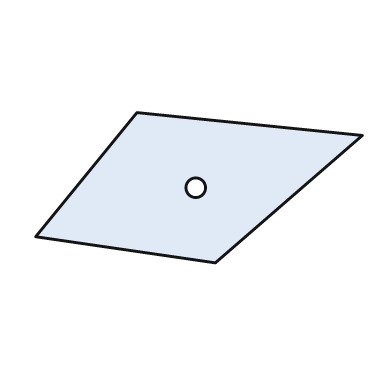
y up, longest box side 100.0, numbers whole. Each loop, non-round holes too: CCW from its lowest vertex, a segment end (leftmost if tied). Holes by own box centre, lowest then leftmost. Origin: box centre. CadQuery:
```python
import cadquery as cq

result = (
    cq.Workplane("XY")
    .moveTo(5.0, -23.0)
    .lineTo(50.0, 16.0)
    .lineTo(-19.0, 23.0)
    .lineTo(-50.0, -15.0)
    .close()
    .moveTo(-1.0, 0.0)
    .circle(3.0)
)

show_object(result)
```